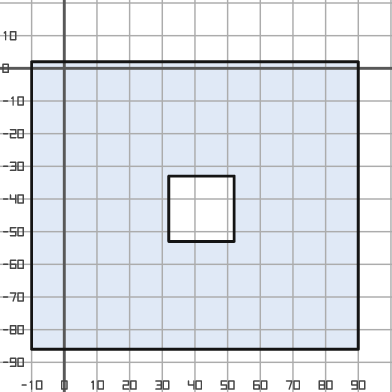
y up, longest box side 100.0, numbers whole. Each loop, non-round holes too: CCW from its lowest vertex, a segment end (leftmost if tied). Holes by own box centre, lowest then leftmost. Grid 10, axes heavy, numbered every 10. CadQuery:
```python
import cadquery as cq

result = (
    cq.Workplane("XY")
    .moveTo(-10.0, -86.0)
    .lineTo(90.0, -86.0)
    .lineTo(90.0, 2.0)
    .lineTo(-10.0, 2.0)
    .close()
    .moveTo(32.0, -53.0)
    .lineTo(52.0, -53.0)
    .lineTo(52.0, -33.0)
    .lineTo(32.0, -33.0)
    .close()
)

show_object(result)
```